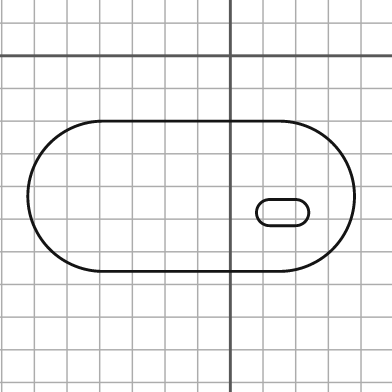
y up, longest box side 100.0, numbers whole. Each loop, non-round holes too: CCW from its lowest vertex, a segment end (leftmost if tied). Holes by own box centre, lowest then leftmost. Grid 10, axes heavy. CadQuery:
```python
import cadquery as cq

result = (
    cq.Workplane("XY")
    .moveTo(-39.0, -66.0)
    .lineTo(15.0, -66.0)
    .threePointArc((38.0, -43.0), (15.0, -20.0))
    .lineTo(-39.0, -20.0)
    .threePointArc((-62.0, -43.0), (-39.0, -66.0))
    .close()
    .moveTo(12.0, -52.0)
    .lineTo(20.0, -52.0)
    .threePointArc((24.0, -48.0), (20.0, -44.0))
    .lineTo(12.0, -44.0)
    .threePointArc((8.0, -48.0), (12.0, -52.0))
    .close()
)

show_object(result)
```